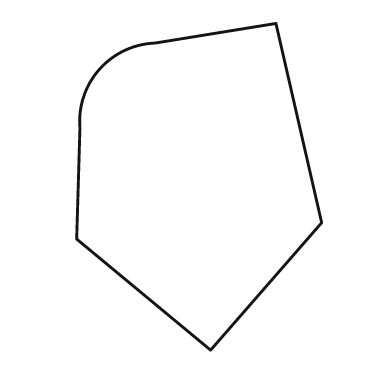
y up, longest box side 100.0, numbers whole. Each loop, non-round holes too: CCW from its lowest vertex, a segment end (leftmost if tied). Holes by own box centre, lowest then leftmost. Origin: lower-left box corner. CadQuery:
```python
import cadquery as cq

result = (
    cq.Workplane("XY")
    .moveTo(41.0, 0.0)
    .lineTo(75.0, 39.0)
    .lineTo(61.0, 100.0)
    .lineTo(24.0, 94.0)
    .threePointArc((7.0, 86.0), (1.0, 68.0))
    .lineTo(0.0, 34.0)
    .close()
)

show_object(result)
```